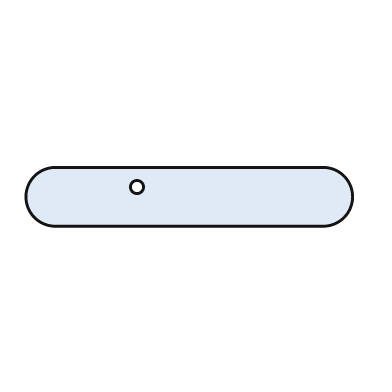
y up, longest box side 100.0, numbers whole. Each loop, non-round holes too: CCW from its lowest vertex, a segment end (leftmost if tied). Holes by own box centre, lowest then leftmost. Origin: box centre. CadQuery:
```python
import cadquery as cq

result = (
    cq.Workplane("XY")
    .moveTo(-41.0, -9.0)
    .lineTo(41.0, -9.0)
    .threePointArc((50.0, 0.0), (41.0, 9.0))
    .lineTo(-41.0, 9.0)
    .threePointArc((-50.0, 0.0), (-41.0, -9.0))
    .close()
    .moveTo(-16.0, 3.0)
    .circle(2.0)
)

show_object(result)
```